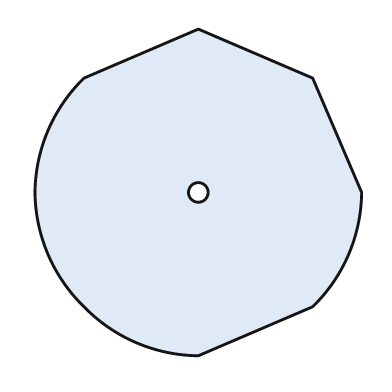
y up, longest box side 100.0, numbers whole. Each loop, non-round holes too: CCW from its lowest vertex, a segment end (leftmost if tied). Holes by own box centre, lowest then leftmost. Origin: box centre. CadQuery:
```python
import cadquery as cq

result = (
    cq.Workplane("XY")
    .moveTo(0.0, -50.0)
    .lineTo(35.0, -35.0)
    .threePointArc((46.0, -19.0), (50.0, 0.0))
    .lineTo(35.0, 35.0)
    .lineTo(0.0, 50.0)
    .lineTo(-35.0, 35.0)
    .threePointArc((-46.0, 19.0), (-50.0, 0.0))
    .threePointArc((-46.0, -19.0), (-35.0, -35.0))
    .threePointArc((-19.0, -46.0), (0.0, -50.0))
    .close()
    .moveTo(0.0, 0.0)
    .circle(3.0)
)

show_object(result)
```